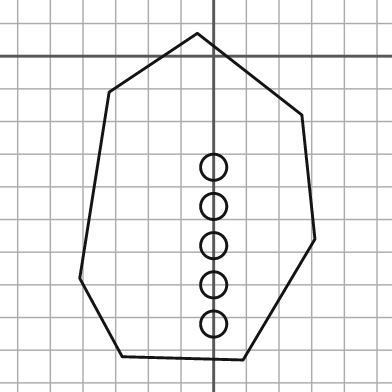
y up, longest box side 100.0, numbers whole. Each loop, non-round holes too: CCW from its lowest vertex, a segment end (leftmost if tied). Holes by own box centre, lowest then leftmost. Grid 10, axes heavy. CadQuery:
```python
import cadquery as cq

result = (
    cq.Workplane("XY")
    .moveTo(9.0, -93.0)
    .lineTo(31.0, -56.0)
    .lineTo(27.0, -18.0)
    .lineTo(-5.0, 7.0)
    .lineTo(-32.0, -11.0)
    .lineTo(-41.0, -68.0)
    .lineTo(-28.0, -92.0)
    .close()
    .moveTo(0.0, -82.0)
    .circle(4.0)
    .moveTo(0.0, -70.0)
    .circle(4.0)
    .moveTo(0.0, -58.0)
    .circle(4.0)
    .moveTo(0.0, -46.0)
    .circle(4.0)
    .moveTo(0.0, -34.0)
    .circle(4.0)
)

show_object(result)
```